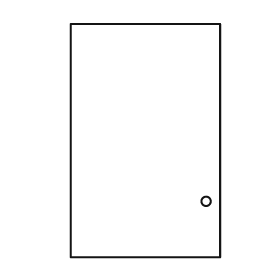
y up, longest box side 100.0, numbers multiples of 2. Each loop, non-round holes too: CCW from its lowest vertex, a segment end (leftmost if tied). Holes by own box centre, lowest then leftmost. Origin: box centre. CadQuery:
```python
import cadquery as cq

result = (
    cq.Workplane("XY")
    .moveTo(-32.0, -50.0)
    .lineTo(32.0, -50.0)
    .lineTo(32.0, 50.0)
    .lineTo(-32.0, 50.0)
    .close()
    .moveTo(26.0, -26.0)
    .circle(2.0)
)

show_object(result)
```